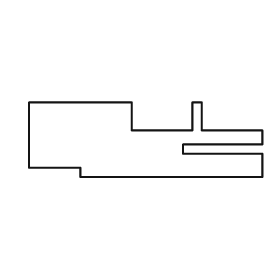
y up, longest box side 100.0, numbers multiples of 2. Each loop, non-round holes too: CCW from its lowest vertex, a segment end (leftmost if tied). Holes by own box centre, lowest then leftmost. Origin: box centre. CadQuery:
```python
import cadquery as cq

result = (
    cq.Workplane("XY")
    .moveTo(-28.0, -16.0)
    .lineTo(50.0, -16.0)
    .lineTo(50.0, -6.0)
    .lineTo(16.0, -6.0)
    .lineTo(16.0, -2.0)
    .lineTo(50.0, -2.0)
    .lineTo(50.0, 4.0)
    .lineTo(24.0, 4.0)
    .lineTo(24.0, 16.0)
    .lineTo(20.0, 16.0)
    .lineTo(20.0, 4.0)
    .lineTo(-6.0, 4.0)
    .lineTo(-6.0, 16.0)
    .lineTo(-50.0, 16.0)
    .lineTo(-50.0, -12.0)
    .lineTo(-28.0, -12.0)
    .close()
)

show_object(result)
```